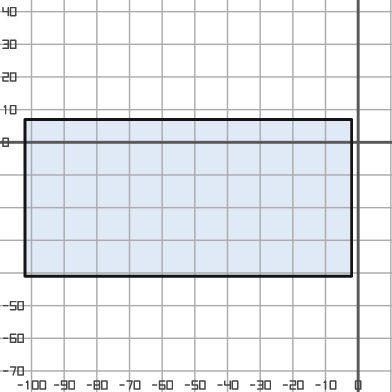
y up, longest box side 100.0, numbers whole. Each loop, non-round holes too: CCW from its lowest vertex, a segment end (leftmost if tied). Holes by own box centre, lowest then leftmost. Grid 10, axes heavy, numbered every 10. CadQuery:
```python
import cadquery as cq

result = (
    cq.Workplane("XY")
    .moveTo(-102.0, -41.0)
    .lineTo(-2.0, -41.0)
    .lineTo(-2.0, 7.0)
    .lineTo(-102.0, 7.0)
    .close()
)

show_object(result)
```